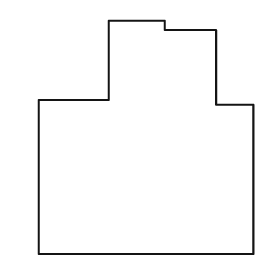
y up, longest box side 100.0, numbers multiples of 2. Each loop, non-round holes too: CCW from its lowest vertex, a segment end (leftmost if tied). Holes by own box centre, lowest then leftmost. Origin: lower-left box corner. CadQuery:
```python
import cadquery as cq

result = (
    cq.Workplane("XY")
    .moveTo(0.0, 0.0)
    .lineTo(92.0, 0.0)
    .lineTo(92.0, 64.0)
    .lineTo(76.0, 64.0)
    .lineTo(76.0, 96.0)
    .lineTo(54.0, 96.0)
    .lineTo(54.0, 100.0)
    .lineTo(30.0, 100.0)
    .lineTo(30.0, 66.0)
    .lineTo(0.0, 66.0)
    .close()
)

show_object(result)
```